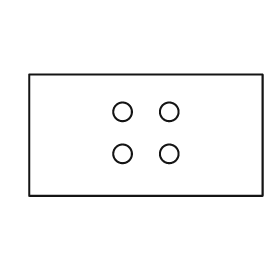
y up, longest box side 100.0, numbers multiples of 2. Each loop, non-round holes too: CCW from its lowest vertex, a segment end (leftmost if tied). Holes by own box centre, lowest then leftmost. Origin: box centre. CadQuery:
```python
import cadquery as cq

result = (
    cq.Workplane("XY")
    .moveTo(-50.0, -26.0)
    .lineTo(50.0, -26.0)
    .lineTo(50.0, 26.0)
    .lineTo(-50.0, 26.0)
    .close()
    .moveTo(-10.0, -8.0)
    .circle(4.0)
    .moveTo(10.0, -8.0)
    .circle(4.0)
    .moveTo(-10.0, 10.0)
    .circle(4.0)
    .moveTo(10.0, 10.0)
    .circle(4.0)
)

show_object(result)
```